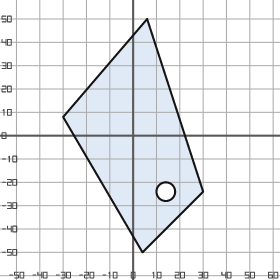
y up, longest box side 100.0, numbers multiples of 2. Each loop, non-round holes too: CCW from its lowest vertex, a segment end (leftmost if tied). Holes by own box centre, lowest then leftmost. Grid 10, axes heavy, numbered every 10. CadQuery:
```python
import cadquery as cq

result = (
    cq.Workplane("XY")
    .moveTo(4.0, -50.0)
    .lineTo(30.0, -24.0)
    .lineTo(6.0, 50.0)
    .lineTo(-30.0, 8.0)
    .close()
    .moveTo(14.0, -24.0)
    .circle(4.0)
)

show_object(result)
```